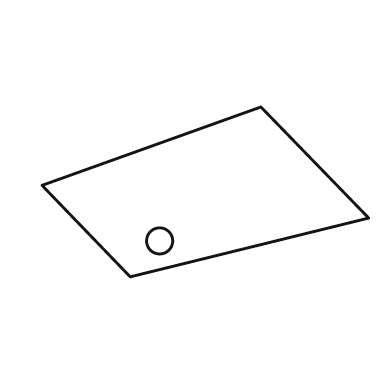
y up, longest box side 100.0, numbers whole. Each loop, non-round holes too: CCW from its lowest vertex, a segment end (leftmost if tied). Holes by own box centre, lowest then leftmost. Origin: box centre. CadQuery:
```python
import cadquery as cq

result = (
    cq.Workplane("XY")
    .moveTo(-23.0, -26.0)
    .lineTo(50.0, -8.0)
    .lineTo(17.0, 26.0)
    .lineTo(-50.0, 2.0)
    .close()
    .moveTo(-14.0, -15.0)
    .circle(4.0)
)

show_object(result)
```